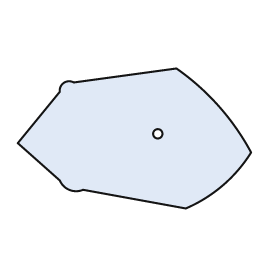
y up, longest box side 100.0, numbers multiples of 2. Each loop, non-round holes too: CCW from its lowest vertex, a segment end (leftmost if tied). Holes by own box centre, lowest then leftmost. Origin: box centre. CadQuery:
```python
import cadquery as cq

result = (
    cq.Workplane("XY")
    .moveTo(22.0, -30.0)
    .threePointArc((38.0, -20.0), (50.0, -6.0))
    .threePointArc((36.0, 14.0), (18.0, 30.0))
    .lineTo(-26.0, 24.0)
    .threePointArc((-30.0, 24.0), (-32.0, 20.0))
    .lineTo(-50.0, -2.0)
    .lineTo(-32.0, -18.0)
    .threePointArc((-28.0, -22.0), (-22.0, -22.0))
    .close()
    .moveTo(10.0, 2.0)
    .circle(2.0)
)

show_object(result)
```